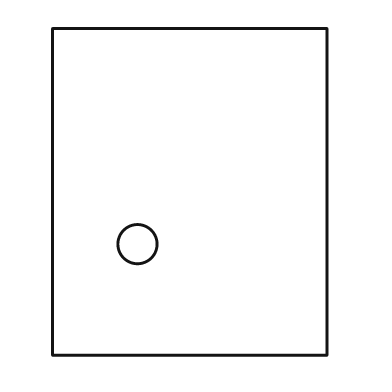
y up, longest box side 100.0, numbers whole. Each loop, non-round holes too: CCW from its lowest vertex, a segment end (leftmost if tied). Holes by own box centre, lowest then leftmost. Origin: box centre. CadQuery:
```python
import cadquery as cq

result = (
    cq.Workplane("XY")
    .moveTo(-42.0, -50.0)
    .lineTo(42.0, -50.0)
    .lineTo(42.0, 50.0)
    .lineTo(-42.0, 50.0)
    .close()
    .moveTo(-16.0, -16.0)
    .circle(6.0)
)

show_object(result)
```